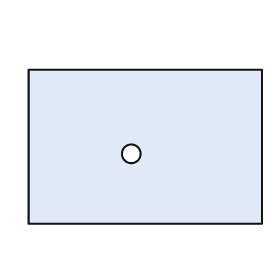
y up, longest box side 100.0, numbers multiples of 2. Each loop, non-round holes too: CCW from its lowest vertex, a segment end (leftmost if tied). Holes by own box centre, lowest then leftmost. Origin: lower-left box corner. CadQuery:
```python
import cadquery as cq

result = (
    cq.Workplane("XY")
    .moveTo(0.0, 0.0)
    .lineTo(100.0, 0.0)
    .lineTo(100.0, 66.0)
    .lineTo(0.0, 66.0)
    .close()
    .moveTo(44.0, 30.0)
    .circle(4.0)
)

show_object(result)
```